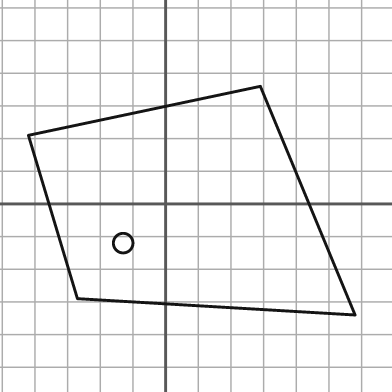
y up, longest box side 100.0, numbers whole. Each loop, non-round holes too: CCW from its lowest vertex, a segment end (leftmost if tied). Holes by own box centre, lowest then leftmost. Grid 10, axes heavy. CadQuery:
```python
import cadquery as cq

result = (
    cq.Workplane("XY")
    .moveTo(58.0, -34.0)
    .lineTo(29.0, 36.0)
    .lineTo(-42.0, 21.0)
    .lineTo(-27.0, -29.0)
    .close()
    .moveTo(-13.0, -12.0)
    .circle(3.0)
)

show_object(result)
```